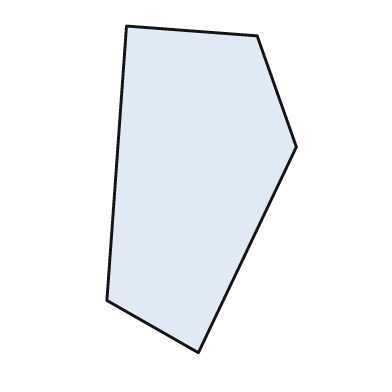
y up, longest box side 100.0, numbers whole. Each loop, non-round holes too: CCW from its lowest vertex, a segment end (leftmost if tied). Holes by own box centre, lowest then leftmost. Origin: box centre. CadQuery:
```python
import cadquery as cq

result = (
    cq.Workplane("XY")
    .moveTo(-1.0, -50.0)
    .lineTo(29.0, 13.0)
    .lineTo(17.0, 47.0)
    .lineTo(-23.0, 50.0)
    .lineTo(-29.0, -34.0)
    .close()
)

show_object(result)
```